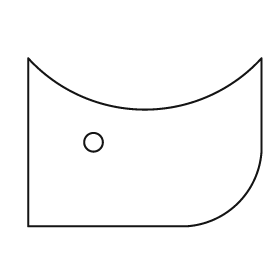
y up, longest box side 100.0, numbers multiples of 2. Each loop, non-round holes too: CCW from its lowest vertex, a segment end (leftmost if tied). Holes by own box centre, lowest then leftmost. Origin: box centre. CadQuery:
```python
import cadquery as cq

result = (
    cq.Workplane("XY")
    .moveTo(-50.0, -36.0)
    .lineTo(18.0, -36.0)
    .threePointArc((40.0, -26.0), (50.0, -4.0))
    .lineTo(50.0, 36.0)
    .threePointArc((0.0, 14.0), (-50.0, 36.0))
    .close()
    .moveTo(-22.0, 0.0)
    .circle(4.0)
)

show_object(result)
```